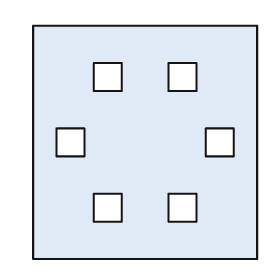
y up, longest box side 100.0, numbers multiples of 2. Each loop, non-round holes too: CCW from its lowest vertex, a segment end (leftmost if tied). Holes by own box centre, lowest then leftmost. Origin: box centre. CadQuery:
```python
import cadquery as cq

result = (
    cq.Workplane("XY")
    .moveTo(-48.0, -50.0)
    .lineTo(48.0, -50.0)
    .lineTo(48.0, 50.0)
    .lineTo(-48.0, 50.0)
    .close()
    .moveTo(-22.0, -34.0)
    .lineTo(-10.0, -34.0)
    .lineTo(-10.0, -22.0)
    .lineTo(-22.0, -22.0)
    .close()
    .moveTo(10.0, -34.0)
    .lineTo(22.0, -34.0)
    .lineTo(22.0, -22.0)
    .lineTo(10.0, -22.0)
    .close()
    .moveTo(-38.0, -6.0)
    .lineTo(-26.0, -6.0)
    .lineTo(-26.0, 6.0)
    .lineTo(-38.0, 6.0)
    .close()
    .moveTo(26.0, -6.0)
    .lineTo(38.0, -6.0)
    .lineTo(38.0, 6.0)
    .lineTo(26.0, 6.0)
    .close()
    .moveTo(-22.0, 22.0)
    .lineTo(-10.0, 22.0)
    .lineTo(-10.0, 34.0)
    .lineTo(-22.0, 34.0)
    .close()
    .moveTo(10.0, 22.0)
    .lineTo(22.0, 22.0)
    .lineTo(22.0, 34.0)
    .lineTo(10.0, 34.0)
    .close()
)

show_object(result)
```